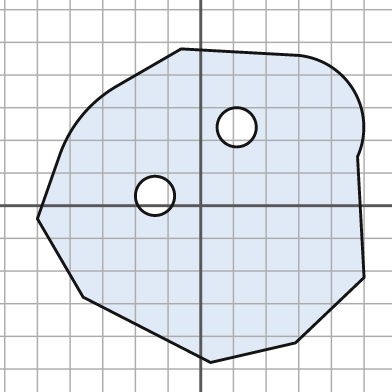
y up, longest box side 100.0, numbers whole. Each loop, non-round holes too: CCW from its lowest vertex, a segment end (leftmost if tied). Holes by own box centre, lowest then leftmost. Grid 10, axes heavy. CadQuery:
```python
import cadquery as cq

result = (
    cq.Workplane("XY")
    .moveTo(3.0, -48.0)
    .lineTo(29.0, -42.0)
    .lineTo(50.0, -22.0)
    .lineTo(48.0, 15.0)
    .threePointArc((47.0, 35.0), (30.0, 46.0))
    .lineTo(-6.0, 48.0)
    .lineTo(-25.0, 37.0)
    .threePointArc((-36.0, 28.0), (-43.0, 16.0))
    .lineTo(-50.0, -4.0)
    .lineTo(-36.0, -28.0)
    .close()
    .moveTo(-14.0, 3.0)
    .circle(6.0)
    .moveTo(11.0, 24.0)
    .circle(6.0)
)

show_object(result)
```